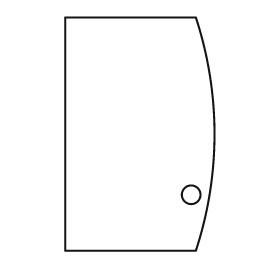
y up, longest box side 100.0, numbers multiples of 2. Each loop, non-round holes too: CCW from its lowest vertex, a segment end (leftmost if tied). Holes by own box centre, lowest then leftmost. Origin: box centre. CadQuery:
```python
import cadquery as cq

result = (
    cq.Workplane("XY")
    .moveTo(-32.0, -50.0)
    .lineTo(24.0, -50.0)
    .threePointArc((32.0, 0.0), (24.0, 50.0))
    .lineTo(-32.0, 50.0)
    .close()
    .moveTo(22.0, -26.0)
    .circle(4.0)
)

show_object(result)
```